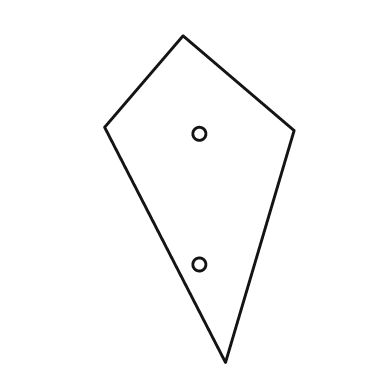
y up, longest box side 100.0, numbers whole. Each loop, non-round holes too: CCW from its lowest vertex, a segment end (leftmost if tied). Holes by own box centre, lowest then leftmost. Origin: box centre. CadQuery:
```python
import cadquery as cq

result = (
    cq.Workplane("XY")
    .moveTo(8.0, -50.0)
    .lineTo(29.0, 21.0)
    .lineTo(-5.0, 50.0)
    .lineTo(-29.0, 22.0)
    .close()
    .moveTo(0.0, -20.0)
    .circle(2.0)
    .moveTo(0.0, 20.0)
    .circle(2.0)
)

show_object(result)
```